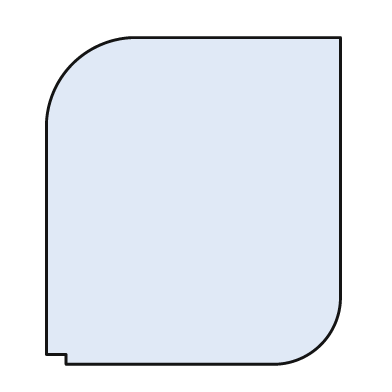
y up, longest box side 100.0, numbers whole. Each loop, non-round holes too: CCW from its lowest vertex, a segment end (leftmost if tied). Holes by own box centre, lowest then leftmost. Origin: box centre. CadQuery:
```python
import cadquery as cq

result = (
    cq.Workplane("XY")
    .moveTo(-39.0, -50.0)
    .lineTo(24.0, -50.0)
    .threePointArc((39.0, -44.0), (45.0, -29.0))
    .lineTo(45.0, 50.0)
    .lineTo(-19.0, 50.0)
    .threePointArc((-37.0, 42.0), (-45.0, 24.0))
    .lineTo(-45.0, -47.0)
    .lineTo(-39.0, -47.0)
    .close()
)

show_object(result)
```